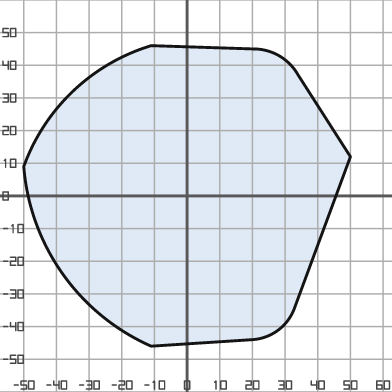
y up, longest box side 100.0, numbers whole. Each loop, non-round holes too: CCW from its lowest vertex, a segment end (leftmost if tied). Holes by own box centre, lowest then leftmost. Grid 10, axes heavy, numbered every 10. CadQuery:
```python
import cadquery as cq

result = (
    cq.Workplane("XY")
    .moveTo(-11.0, -46.0)
    .lineTo(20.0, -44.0)
    .threePointArc((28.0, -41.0), (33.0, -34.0))
    .lineTo(50.0, 12.0)
    .lineTo(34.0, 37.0)
    .threePointArc((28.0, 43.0), (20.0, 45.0))
    .lineTo(-11.0, 46.0)
    .threePointArc((-35.0, 32.0), (-50.0, 9.0))
    .threePointArc((-38.0, -24.0), (-11.0, -46.0))
    .close()
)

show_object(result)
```